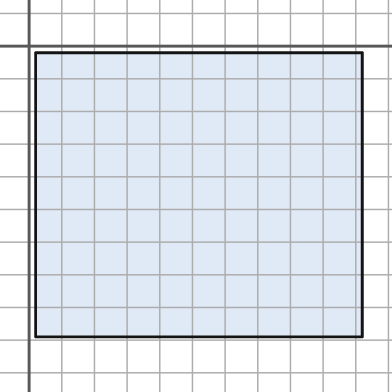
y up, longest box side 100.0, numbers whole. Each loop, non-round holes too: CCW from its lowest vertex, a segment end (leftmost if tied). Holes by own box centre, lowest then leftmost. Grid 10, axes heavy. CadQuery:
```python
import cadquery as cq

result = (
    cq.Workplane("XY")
    .moveTo(2.0, -89.0)
    .lineTo(102.0, -89.0)
    .lineTo(102.0, -2.0)
    .lineTo(2.0, -2.0)
    .close()
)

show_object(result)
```